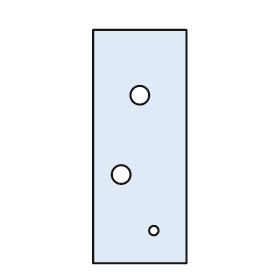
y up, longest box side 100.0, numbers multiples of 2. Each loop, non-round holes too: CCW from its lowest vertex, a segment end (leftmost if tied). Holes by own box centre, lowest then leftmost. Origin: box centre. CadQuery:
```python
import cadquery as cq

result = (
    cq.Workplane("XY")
    .moveTo(-20.0, -50.0)
    .lineTo(20.0, -50.0)
    .lineTo(20.0, 50.0)
    .lineTo(-20.0, 50.0)
    .close()
    .moveTo(6.0, -36.0)
    .circle(2.0)
    .moveTo(-8.0, -12.0)
    .circle(4.0)
    .moveTo(0.0, 22.0)
    .circle(4.0)
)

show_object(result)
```